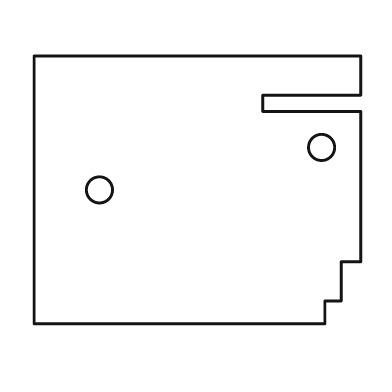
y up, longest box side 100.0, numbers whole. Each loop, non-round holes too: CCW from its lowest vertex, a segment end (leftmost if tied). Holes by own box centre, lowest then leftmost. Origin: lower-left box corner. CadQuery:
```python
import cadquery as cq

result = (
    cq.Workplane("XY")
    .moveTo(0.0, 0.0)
    .lineTo(89.0, 0.0)
    .lineTo(89.0, 7.0)
    .lineTo(94.0, 7.0)
    .lineTo(94.0, 19.0)
    .lineTo(100.0, 19.0)
    .lineTo(100.0, 65.0)
    .lineTo(70.0, 65.0)
    .lineTo(70.0, 70.0)
    .lineTo(100.0, 70.0)
    .lineTo(100.0, 82.0)
    .lineTo(0.0, 82.0)
    .close()
    .moveTo(20.0, 41.0)
    .circle(4.0)
    .moveTo(88.0, 54.0)
    .circle(4.0)
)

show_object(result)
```